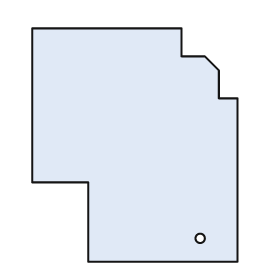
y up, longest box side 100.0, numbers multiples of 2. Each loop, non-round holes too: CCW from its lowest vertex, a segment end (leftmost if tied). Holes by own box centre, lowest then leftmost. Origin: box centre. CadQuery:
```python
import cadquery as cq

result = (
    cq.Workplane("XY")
    .moveTo(-20.0, -50.0)
    .lineTo(44.0, -50.0)
    .lineTo(44.0, 20.0)
    .lineTo(36.0, 20.0)
    .lineTo(36.0, 32.0)
    .lineTo(30.0, 38.0)
    .lineTo(20.0, 38.0)
    .lineTo(20.0, 50.0)
    .lineTo(-44.0, 50.0)
    .lineTo(-44.0, -16.0)
    .lineTo(-20.0, -16.0)
    .close()
    .moveTo(28.0, -40.0)
    .circle(2.0)
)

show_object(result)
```